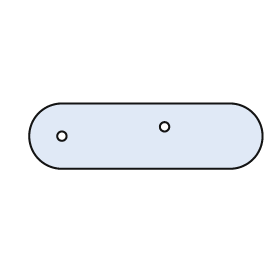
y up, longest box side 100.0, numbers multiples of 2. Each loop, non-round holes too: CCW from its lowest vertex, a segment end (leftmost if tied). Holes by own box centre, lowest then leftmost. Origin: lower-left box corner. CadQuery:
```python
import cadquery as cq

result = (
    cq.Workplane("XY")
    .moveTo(14.0, 0.0)
    .lineTo(86.0, 0.0)
    .threePointArc((100.0, 14.0), (86.0, 28.0))
    .lineTo(14.0, 28.0)
    .threePointArc((0.0, 14.0), (14.0, 0.0))
    .close()
    .moveTo(14.0, 14.0)
    .circle(2.0)
    .moveTo(58.0, 18.0)
    .circle(2.0)
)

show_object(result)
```